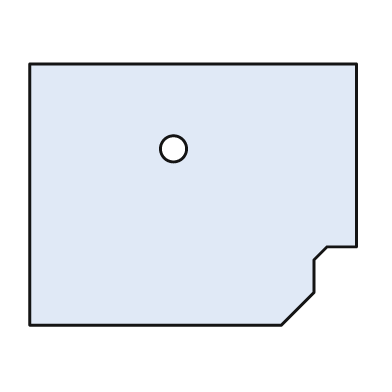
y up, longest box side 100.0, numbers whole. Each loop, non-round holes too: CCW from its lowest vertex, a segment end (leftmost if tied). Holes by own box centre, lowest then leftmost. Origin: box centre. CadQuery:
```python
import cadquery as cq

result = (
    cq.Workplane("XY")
    .moveTo(-50.0, -40.0)
    .lineTo(27.0, -40.0)
    .lineTo(37.0, -30.0)
    .lineTo(37.0, -20.0)
    .lineTo(41.0, -16.0)
    .lineTo(50.0, -16.0)
    .lineTo(50.0, 40.0)
    .lineTo(-50.0, 40.0)
    .close()
    .moveTo(-6.0, 14.0)
    .circle(4.0)
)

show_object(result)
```